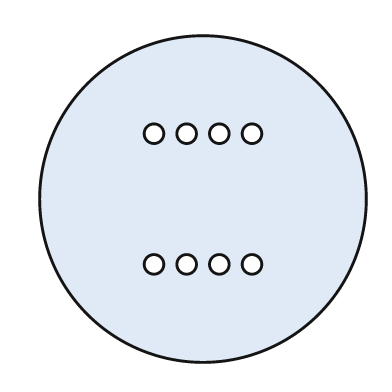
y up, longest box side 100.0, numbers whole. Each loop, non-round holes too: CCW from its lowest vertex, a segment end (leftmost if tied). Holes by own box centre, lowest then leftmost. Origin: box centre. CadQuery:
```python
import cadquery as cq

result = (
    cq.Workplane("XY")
    .moveTo(0.0, 0.0)
    .circle(50.0)
    .moveTo(-15.0, -20.0)
    .circle(3.0)
    .moveTo(-5.0, -20.0)
    .circle(3.0)
    .moveTo(5.0, -20.0)
    .circle(3.0)
    .moveTo(15.0, -20.0)
    .circle(3.0)
    .moveTo(-15.0, 20.0)
    .circle(3.0)
    .moveTo(-5.0, 20.0)
    .circle(3.0)
    .moveTo(5.0, 20.0)
    .circle(3.0)
    .moveTo(15.0, 20.0)
    .circle(3.0)
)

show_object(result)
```